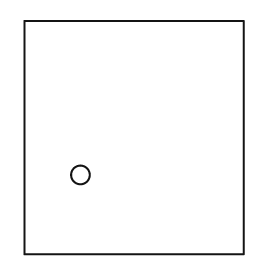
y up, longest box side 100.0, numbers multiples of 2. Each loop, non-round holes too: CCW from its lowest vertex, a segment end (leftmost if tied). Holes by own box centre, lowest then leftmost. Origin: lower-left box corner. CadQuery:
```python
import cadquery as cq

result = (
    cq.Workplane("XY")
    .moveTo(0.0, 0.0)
    .lineTo(94.0, 0.0)
    .lineTo(94.0, 100.0)
    .lineTo(0.0, 100.0)
    .close()
    .moveTo(24.0, 34.0)
    .circle(4.0)
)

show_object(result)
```